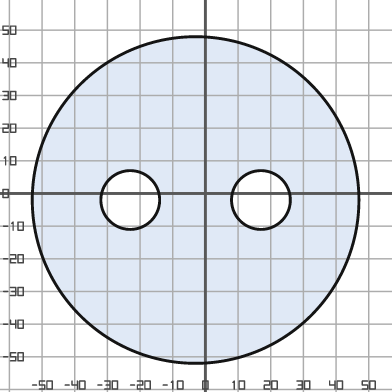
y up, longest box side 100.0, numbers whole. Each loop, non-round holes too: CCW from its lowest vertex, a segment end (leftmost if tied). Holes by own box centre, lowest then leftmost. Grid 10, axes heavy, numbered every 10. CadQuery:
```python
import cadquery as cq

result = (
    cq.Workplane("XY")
    .moveTo(-3.0, -2.0)
    .circle(50.0)
    .moveTo(-23.0, -2.0)
    .circle(9.0)
    .moveTo(17.0, -2.0)
    .circle(9.0)
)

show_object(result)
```